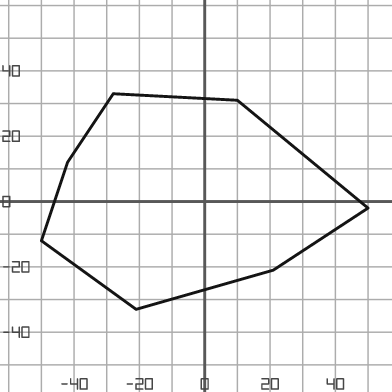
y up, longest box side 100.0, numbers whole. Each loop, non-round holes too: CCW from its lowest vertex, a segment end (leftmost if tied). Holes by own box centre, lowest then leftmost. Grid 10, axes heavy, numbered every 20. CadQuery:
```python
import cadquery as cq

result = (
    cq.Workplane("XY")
    .moveTo(-21.0, -33.0)
    .lineTo(21.0, -21.0)
    .lineTo(50.0, -2.0)
    .lineTo(10.0, 31.0)
    .lineTo(-28.0, 33.0)
    .lineTo(-42.0, 12.0)
    .lineTo(-50.0, -12.0)
    .close()
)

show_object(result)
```